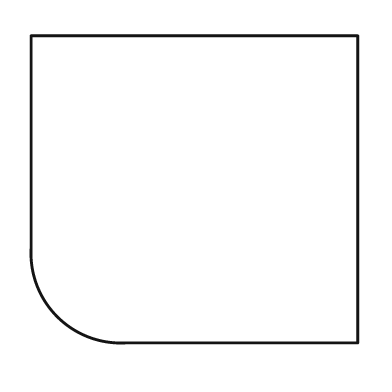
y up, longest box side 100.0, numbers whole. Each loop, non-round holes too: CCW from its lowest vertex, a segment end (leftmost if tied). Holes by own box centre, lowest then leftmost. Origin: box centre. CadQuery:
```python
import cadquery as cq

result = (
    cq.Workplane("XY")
    .moveTo(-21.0, -47.0)
    .lineTo(50.0, -47.0)
    .lineTo(50.0, 47.0)
    .lineTo(-50.0, 47.0)
    .lineTo(-50.0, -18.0)
    .threePointArc((-42.0, -39.0), (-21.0, -47.0))
    .close()
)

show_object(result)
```